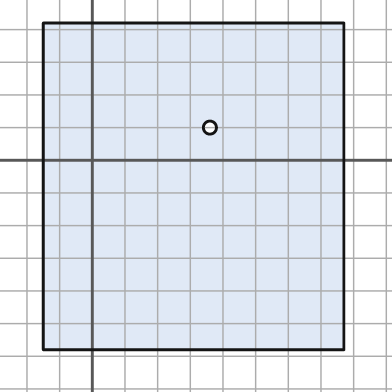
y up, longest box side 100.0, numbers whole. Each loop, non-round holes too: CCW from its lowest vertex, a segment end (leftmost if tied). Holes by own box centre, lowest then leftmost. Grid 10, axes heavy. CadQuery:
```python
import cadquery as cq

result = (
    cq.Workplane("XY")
    .moveTo(-15.0, -58.0)
    .lineTo(77.0, -58.0)
    .lineTo(77.0, 42.0)
    .lineTo(-15.0, 42.0)
    .close()
    .moveTo(36.0, 10.0)
    .circle(2.0)
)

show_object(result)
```